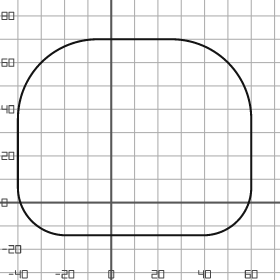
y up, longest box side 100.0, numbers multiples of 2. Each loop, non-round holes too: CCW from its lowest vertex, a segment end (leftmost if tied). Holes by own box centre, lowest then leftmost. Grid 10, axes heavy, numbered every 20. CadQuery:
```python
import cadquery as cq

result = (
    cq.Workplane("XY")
    .moveTo(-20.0, -14.0)
    .lineTo(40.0, -14.0)
    .threePointArc((54.0, -8.0), (60.0, 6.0))
    .lineTo(60.0, 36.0)
    .threePointArc((50.0, 60.0), (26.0, 70.0))
    .lineTo(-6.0, 70.0)
    .threePointArc((-30.0, 60.0), (-40.0, 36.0))
    .lineTo(-40.0, 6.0)
    .threePointArc((-34.0, -8.0), (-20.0, -14.0))
    .close()
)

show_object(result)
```